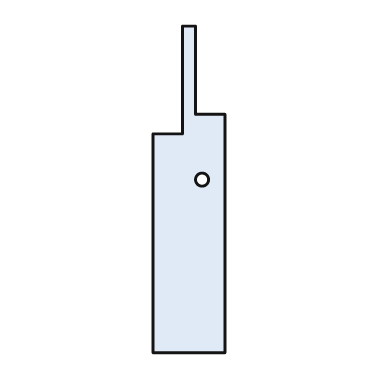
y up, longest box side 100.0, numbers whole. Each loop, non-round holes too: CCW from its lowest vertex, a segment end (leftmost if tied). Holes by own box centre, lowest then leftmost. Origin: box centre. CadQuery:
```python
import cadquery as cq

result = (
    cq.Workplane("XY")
    .moveTo(-11.0, -50.0)
    .lineTo(11.0, -50.0)
    .lineTo(11.0, 23.0)
    .lineTo(2.0, 23.0)
    .lineTo(2.0, 50.0)
    .lineTo(-2.0, 50.0)
    .lineTo(-2.0, 17.0)
    .lineTo(-11.0, 17.0)
    .close()
    .moveTo(4.0, 3.0)
    .circle(2.0)
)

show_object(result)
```